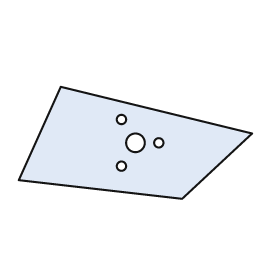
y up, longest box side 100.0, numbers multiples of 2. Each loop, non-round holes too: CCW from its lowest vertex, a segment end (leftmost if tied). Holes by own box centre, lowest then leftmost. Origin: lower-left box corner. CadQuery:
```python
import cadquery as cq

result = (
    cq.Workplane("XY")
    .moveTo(70.0, 0.0)
    .lineTo(100.0, 28.0)
    .lineTo(18.0, 48.0)
    .lineTo(0.0, 8.0)
    .close()
    .moveTo(44.0, 14.0)
    .circle(2.0)
    .moveTo(50.0, 24.0)
    .circle(4.0)
    .moveTo(60.0, 24.0)
    .circle(2.0)
    .moveTo(44.0, 34.0)
    .circle(2.0)
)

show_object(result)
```